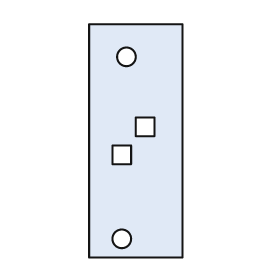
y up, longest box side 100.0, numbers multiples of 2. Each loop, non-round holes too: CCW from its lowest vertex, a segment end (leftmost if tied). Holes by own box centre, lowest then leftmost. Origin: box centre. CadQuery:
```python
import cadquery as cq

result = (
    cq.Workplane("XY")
    .moveTo(-20.0, -50.0)
    .lineTo(20.0, -50.0)
    .lineTo(20.0, 50.0)
    .lineTo(-20.0, 50.0)
    .close()
    .moveTo(-6.0, -42.0)
    .circle(4.0)
    .moveTo(-10.0, -10.0)
    .lineTo(-2.0, -10.0)
    .lineTo(-2.0, -2.0)
    .lineTo(-10.0, -2.0)
    .close()
    .moveTo(0.0, 2.0)
    .lineTo(8.0, 2.0)
    .lineTo(8.0, 10.0)
    .lineTo(0.0, 10.0)
    .close()
    .moveTo(-4.0, 36.0)
    .circle(4.0)
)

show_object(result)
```